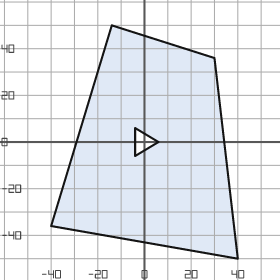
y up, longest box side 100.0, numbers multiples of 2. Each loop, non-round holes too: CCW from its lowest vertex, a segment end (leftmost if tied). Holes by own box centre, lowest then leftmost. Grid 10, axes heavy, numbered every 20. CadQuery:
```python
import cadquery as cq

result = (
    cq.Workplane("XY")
    .moveTo(40.0, -50.0)
    .lineTo(30.0, 36.0)
    .lineTo(-14.0, 50.0)
    .lineTo(-40.0, -36.0)
    .close()
    .moveTo(-4.0, -6.0)
    .lineTo(6.0, 0.0)
    .lineTo(-4.0, 6.0)
    .close()
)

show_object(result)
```